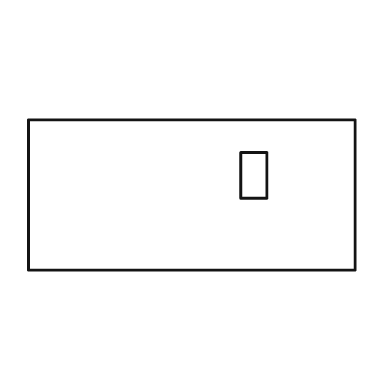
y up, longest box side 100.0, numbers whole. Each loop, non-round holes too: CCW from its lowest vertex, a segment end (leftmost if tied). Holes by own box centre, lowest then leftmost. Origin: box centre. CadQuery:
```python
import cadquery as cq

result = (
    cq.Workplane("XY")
    .moveTo(-50.0, -23.0)
    .lineTo(50.0, -23.0)
    .lineTo(50.0, 23.0)
    .lineTo(-50.0, 23.0)
    .close()
    .moveTo(15.0, -1.0)
    .lineTo(23.0, -1.0)
    .lineTo(23.0, 13.0)
    .lineTo(15.0, 13.0)
    .close()
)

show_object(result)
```